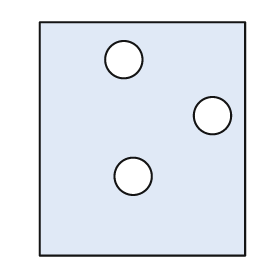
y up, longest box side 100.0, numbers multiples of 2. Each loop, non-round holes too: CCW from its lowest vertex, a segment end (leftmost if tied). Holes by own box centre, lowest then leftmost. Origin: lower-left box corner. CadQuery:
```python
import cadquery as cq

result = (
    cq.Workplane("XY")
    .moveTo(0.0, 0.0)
    .lineTo(88.0, 0.0)
    .lineTo(88.0, 100.0)
    .lineTo(0.0, 100.0)
    .close()
    .moveTo(40.0, 34.0)
    .circle(8.0)
    .moveTo(74.0, 60.0)
    .circle(8.0)
    .moveTo(36.0, 84.0)
    .circle(8.0)
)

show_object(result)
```